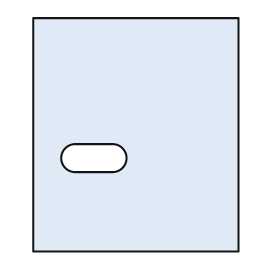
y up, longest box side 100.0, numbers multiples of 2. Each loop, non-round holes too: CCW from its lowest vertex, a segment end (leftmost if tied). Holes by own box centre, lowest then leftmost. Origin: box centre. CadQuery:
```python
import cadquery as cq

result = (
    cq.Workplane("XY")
    .moveTo(-44.0, -50.0)
    .lineTo(44.0, -50.0)
    .lineTo(44.0, 50.0)
    .lineTo(-44.0, 50.0)
    .close()
    .moveTo(-26.0, -16.0)
    .lineTo(-10.0, -16.0)
    .threePointArc((-4.0, -10.0), (-10.0, -4.0))
    .lineTo(-26.0, -4.0)
    .threePointArc((-32.0, -10.0), (-26.0, -16.0))
    .close()
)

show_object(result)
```